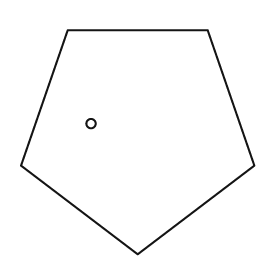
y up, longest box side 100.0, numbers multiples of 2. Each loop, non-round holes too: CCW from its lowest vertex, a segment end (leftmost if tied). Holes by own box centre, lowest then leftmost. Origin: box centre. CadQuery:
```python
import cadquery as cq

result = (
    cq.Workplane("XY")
    .moveTo(0.0, -48.0)
    .lineTo(50.0, -10.0)
    .lineTo(30.0, 48.0)
    .lineTo(-30.0, 48.0)
    .lineTo(-50.0, -10.0)
    .close()
    .moveTo(-20.0, 8.0)
    .circle(2.0)
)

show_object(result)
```